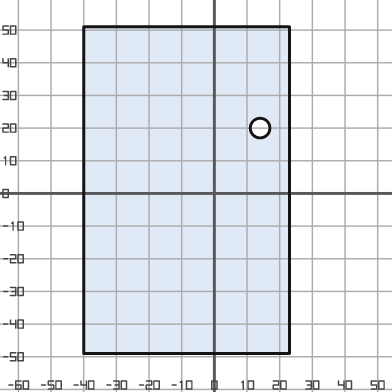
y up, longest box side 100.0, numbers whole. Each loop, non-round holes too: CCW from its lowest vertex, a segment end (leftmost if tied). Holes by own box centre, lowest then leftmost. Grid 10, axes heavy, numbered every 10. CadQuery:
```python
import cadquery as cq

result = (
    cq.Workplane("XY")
    .moveTo(-40.0, -49.0)
    .lineTo(23.0, -49.0)
    .lineTo(23.0, 51.0)
    .lineTo(-40.0, 51.0)
    .close()
    .moveTo(14.0, 20.0)
    .circle(3.0)
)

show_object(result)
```